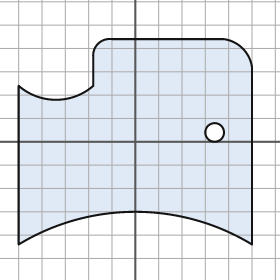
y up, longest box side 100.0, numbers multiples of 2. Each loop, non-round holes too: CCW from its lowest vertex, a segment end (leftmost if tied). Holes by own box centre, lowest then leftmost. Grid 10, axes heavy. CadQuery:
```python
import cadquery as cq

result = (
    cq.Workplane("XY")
    .moveTo(-50.0, -44.0)
    .threePointArc((0.0, -30.0), (50.0, -44.0))
    .lineTo(50.0, 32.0)
    .threePointArc((46.0, 40.0), (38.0, 44.0))
    .lineTo(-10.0, 44.0)
    .threePointArc((-16.0, 42.0), (-18.0, 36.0))
    .lineTo(-18.0, 24.0)
    .threePointArc((-34.0, 18.0), (-50.0, 24.0))
    .close()
    .moveTo(34.0, 4.0)
    .circle(4.0)
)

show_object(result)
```